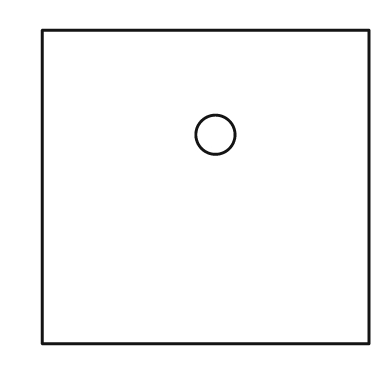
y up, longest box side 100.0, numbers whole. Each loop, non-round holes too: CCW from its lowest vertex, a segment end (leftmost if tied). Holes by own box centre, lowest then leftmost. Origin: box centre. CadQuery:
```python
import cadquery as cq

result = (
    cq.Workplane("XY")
    .moveTo(-50.0, -48.0)
    .lineTo(50.0, -48.0)
    .lineTo(50.0, 48.0)
    .lineTo(-50.0, 48.0)
    .close()
    .moveTo(3.0, 16.0)
    .circle(6.0)
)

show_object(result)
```